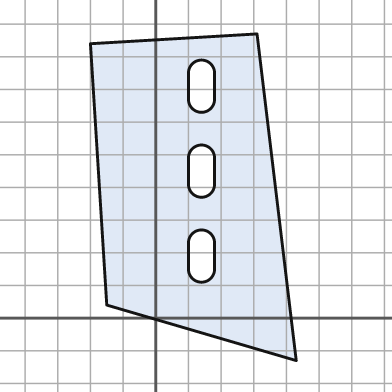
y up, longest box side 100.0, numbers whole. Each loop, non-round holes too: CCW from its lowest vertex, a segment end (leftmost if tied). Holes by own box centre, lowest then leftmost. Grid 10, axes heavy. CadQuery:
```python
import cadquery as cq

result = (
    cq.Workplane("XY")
    .moveTo(43.0, -13.0)
    .lineTo(31.0, 87.0)
    .lineTo(-20.0, 84.0)
    .lineTo(-15.0, 4.0)
    .close()
    .moveTo(10.0, 15.0)
    .threePointArc((14.0, 11.0), (18.0, 15.0))
    .lineTo(18.0, 23.0)
    .threePointArc((14.0, 27.0), (10.0, 23.0))
    .close()
    .moveTo(10.0, 41.0)
    .threePointArc((14.0, 37.0), (18.0, 41.0))
    .lineTo(18.0, 49.0)
    .threePointArc((14.0, 53.0), (10.0, 49.0))
    .close()
    .moveTo(10.0, 67.0)
    .threePointArc((14.0, 63.0), (18.0, 67.0))
    .lineTo(18.0, 75.0)
    .threePointArc((14.0, 79.0), (10.0, 75.0))
    .close()
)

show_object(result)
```